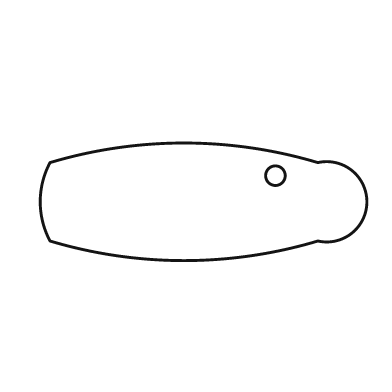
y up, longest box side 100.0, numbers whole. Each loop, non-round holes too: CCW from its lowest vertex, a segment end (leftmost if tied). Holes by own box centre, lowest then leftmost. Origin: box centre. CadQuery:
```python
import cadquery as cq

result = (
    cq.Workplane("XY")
    .moveTo(-47.0, -12.0)
    .threePointArc((-6.0, -18.0), (35.0, -12.0))
    .threePointArc((50.0, 0.0), (35.0, 12.0))
    .threePointArc((-6.0, 18.0), (-47.0, 12.0))
    .threePointArc((-50.0, 0.0), (-47.0, -12.0))
    .close()
    .moveTo(22.0, 8.0)
    .circle(3.0)
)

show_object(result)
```